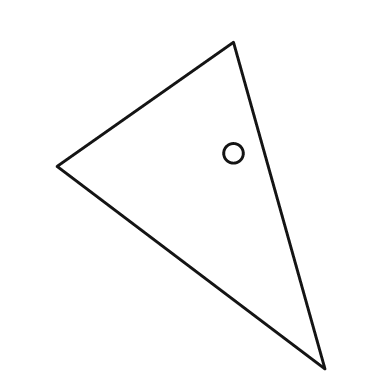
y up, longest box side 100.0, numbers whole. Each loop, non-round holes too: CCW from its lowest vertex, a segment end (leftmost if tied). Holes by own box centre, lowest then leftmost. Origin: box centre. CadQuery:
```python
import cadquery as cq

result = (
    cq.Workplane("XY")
    .moveTo(41.0, -50.0)
    .lineTo(13.0, 50.0)
    .lineTo(-41.0, 12.0)
    .close()
    .moveTo(13.0, 16.0)
    .circle(3.0)
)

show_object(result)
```